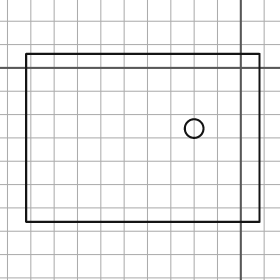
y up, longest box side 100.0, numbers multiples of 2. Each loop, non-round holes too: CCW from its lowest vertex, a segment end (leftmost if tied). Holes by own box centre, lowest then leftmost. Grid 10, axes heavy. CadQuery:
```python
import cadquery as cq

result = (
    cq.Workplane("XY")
    .moveTo(-92.0, -66.0)
    .lineTo(8.0, -66.0)
    .lineTo(8.0, 6.0)
    .lineTo(-92.0, 6.0)
    .close()
    .moveTo(-20.0, -26.0)
    .circle(4.0)
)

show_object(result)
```